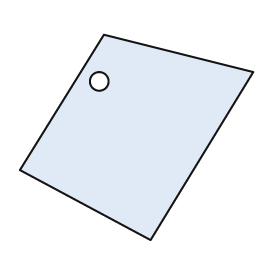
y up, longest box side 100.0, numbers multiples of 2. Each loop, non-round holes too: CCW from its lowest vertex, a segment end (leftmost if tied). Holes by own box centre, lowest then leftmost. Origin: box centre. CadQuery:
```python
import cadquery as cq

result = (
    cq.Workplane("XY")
    .moveTo(6.0, -44.0)
    .lineTo(50.0, 28.0)
    .lineTo(-14.0, 44.0)
    .lineTo(-50.0, -14.0)
    .close()
    .moveTo(-16.0, 24.0)
    .circle(4.0)
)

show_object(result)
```